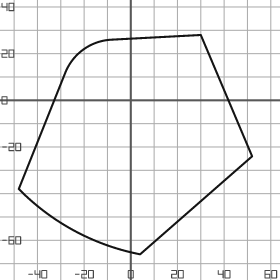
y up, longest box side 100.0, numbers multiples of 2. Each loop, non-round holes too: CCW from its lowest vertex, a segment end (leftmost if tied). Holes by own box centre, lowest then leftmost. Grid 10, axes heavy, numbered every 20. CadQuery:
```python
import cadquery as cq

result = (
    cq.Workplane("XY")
    .moveTo(4.0, -66.0)
    .lineTo(52.0, -24.0)
    .lineTo(30.0, 28.0)
    .lineTo(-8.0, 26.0)
    .threePointArc((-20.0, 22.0), (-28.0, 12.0))
    .lineTo(-48.0, -38.0)
    .threePointArc((-24.0, -56.0), (4.0, -66.0))
    .close()
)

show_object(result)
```